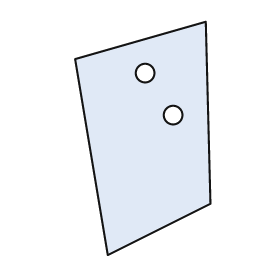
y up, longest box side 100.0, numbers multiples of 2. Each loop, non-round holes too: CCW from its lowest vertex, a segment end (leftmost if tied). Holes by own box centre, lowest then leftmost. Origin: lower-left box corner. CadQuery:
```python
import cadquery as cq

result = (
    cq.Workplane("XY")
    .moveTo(14.0, 0.0)
    .lineTo(58.0, 22.0)
    .lineTo(56.0, 100.0)
    .lineTo(0.0, 84.0)
    .close()
    .moveTo(42.0, 60.0)
    .circle(4.0)
    .moveTo(30.0, 78.0)
    .circle(4.0)
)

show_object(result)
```